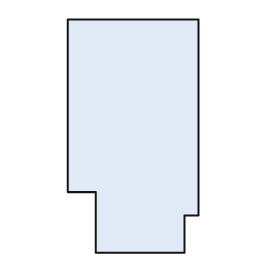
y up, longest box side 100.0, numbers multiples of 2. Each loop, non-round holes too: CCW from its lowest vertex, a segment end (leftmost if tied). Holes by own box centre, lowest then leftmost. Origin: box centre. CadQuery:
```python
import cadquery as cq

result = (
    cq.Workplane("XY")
    .moveTo(-16.0, -50.0)
    .lineTo(22.0, -50.0)
    .lineTo(22.0, -34.0)
    .lineTo(28.0, -34.0)
    .lineTo(28.0, 50.0)
    .lineTo(-28.0, 50.0)
    .lineTo(-28.0, -24.0)
    .lineTo(-16.0, -24.0)
    .close()
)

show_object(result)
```